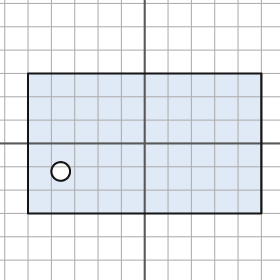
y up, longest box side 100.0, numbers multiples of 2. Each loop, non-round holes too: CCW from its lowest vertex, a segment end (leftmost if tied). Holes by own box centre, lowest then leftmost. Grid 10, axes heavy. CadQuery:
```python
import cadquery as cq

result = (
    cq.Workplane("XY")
    .moveTo(-50.0, -30.0)
    .lineTo(50.0, -30.0)
    .lineTo(50.0, 30.0)
    .lineTo(-50.0, 30.0)
    .close()
    .moveTo(-36.0, -12.0)
    .circle(4.0)
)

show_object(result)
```